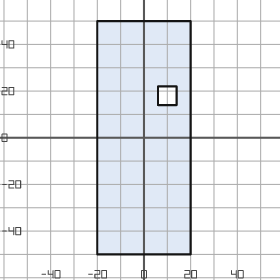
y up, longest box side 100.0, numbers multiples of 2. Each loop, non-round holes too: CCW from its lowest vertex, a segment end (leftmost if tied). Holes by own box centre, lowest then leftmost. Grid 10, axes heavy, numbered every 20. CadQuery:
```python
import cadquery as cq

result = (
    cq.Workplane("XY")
    .moveTo(-20.0, -50.0)
    .lineTo(20.0, -50.0)
    .lineTo(20.0, 50.0)
    .lineTo(-20.0, 50.0)
    .close()
    .moveTo(6.0, 14.0)
    .lineTo(14.0, 14.0)
    .lineTo(14.0, 22.0)
    .lineTo(6.0, 22.0)
    .close()
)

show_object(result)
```